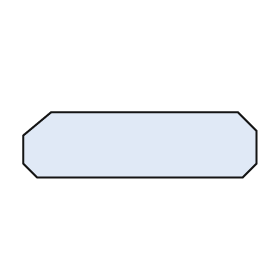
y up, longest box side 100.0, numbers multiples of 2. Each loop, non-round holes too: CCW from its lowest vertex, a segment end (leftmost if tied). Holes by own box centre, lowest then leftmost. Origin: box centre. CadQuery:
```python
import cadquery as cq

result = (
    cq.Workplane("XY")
    .moveTo(-44.0, -14.0)
    .lineTo(44.0, -14.0)
    .lineTo(50.0, -8.0)
    .lineTo(50.0, 6.0)
    .lineTo(42.0, 14.0)
    .lineTo(-38.0, 14.0)
    .lineTo(-50.0, 4.0)
    .lineTo(-50.0, -8.0)
    .close()
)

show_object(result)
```